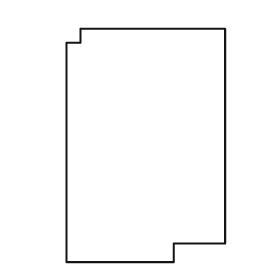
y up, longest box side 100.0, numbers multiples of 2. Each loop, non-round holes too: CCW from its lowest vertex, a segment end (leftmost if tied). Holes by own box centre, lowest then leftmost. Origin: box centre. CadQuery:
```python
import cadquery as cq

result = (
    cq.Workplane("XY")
    .moveTo(-34.0, -50.0)
    .lineTo(12.0, -50.0)
    .lineTo(12.0, -42.0)
    .lineTo(34.0, -42.0)
    .lineTo(34.0, 50.0)
    .lineTo(-28.0, 50.0)
    .lineTo(-28.0, 44.0)
    .lineTo(-34.0, 44.0)
    .close()
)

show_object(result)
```